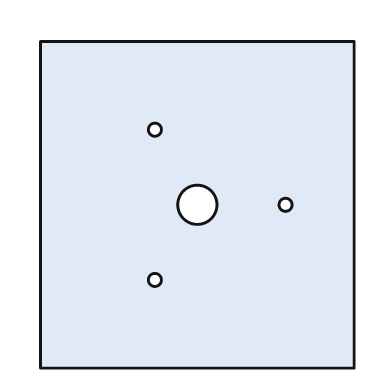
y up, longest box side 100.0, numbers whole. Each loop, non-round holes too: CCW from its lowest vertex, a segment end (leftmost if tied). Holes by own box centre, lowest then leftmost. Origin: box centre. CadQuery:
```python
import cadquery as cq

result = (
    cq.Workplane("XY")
    .moveTo(-48.0, -50.0)
    .lineTo(48.0, -50.0)
    .lineTo(48.0, 50.0)
    .lineTo(-48.0, 50.0)
    .close()
    .moveTo(-13.0, -23.0)
    .circle(2.0)
    .moveTo(0.0, 0.0)
    .circle(6.0)
    .moveTo(27.0, 0.0)
    .circle(2.0)
    .moveTo(-13.0, 23.0)
    .circle(2.0)
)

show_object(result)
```